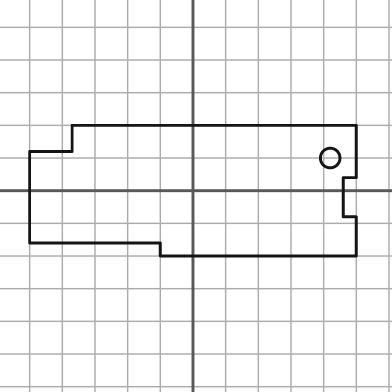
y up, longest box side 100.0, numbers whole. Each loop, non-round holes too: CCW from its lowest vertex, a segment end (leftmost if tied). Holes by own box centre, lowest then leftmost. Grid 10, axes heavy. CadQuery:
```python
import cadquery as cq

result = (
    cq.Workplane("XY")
    .moveTo(-10.0, -20.0)
    .lineTo(50.0, -20.0)
    .lineTo(50.0, -8.0)
    .lineTo(46.0, -8.0)
    .lineTo(46.0, 4.0)
    .lineTo(50.0, 4.0)
    .lineTo(50.0, 20.0)
    .lineTo(-37.0, 20.0)
    .lineTo(-37.0, 12.0)
    .lineTo(-50.0, 12.0)
    .lineTo(-50.0, -16.0)
    .lineTo(-10.0, -16.0)
    .close()
    .moveTo(42.0, 10.0)
    .circle(3.0)
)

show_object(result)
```